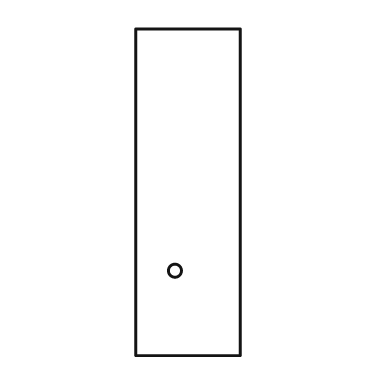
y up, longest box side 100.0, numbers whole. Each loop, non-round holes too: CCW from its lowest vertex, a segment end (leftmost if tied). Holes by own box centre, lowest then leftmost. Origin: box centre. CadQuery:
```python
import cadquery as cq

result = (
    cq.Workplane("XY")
    .moveTo(-16.0, -50.0)
    .lineTo(16.0, -50.0)
    .lineTo(16.0, 50.0)
    .lineTo(-16.0, 50.0)
    .close()
    .moveTo(-4.0, -24.0)
    .circle(2.0)
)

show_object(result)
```